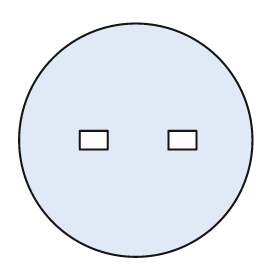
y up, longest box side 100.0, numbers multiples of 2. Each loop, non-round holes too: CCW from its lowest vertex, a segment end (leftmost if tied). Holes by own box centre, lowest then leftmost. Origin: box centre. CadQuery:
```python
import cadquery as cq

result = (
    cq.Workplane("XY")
    .moveTo(0.0, 0.0)
    .circle(50.0)
    .moveTo(-24.0, -4.0)
    .lineTo(-12.0, -4.0)
    .lineTo(-12.0, 4.0)
    .lineTo(-24.0, 4.0)
    .close()
    .moveTo(14.0, -4.0)
    .lineTo(26.0, -4.0)
    .lineTo(26.0, 4.0)
    .lineTo(14.0, 4.0)
    .close()
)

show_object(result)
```